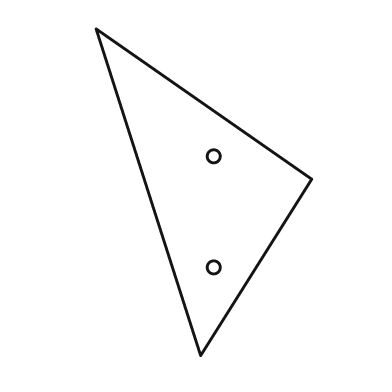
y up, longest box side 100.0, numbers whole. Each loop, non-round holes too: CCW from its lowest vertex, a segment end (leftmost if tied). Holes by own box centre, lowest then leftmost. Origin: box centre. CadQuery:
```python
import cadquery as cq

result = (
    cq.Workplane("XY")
    .moveTo(-1.0, -50.0)
    .lineTo(33.0, 4.0)
    .lineTo(-33.0, 50.0)
    .close()
    .moveTo(3.0, -23.0)
    .circle(2.0)
    .moveTo(3.0, 11.0)
    .circle(2.0)
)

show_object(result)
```